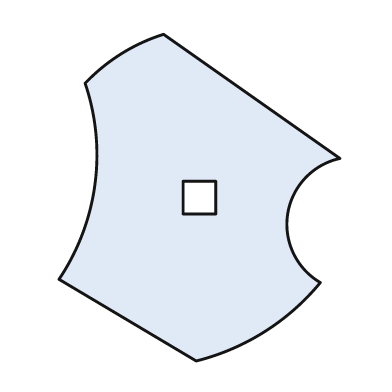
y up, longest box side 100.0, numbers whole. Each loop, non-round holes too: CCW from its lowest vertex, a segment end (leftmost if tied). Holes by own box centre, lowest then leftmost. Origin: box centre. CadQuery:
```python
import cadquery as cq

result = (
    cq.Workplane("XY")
    .moveTo(-1.0, -50.0)
    .threePointArc((20.0, -41.0), (37.0, -26.0))
    .threePointArc((27.0, -5.0), (43.0, 12.0))
    .lineTo(-11.0, 50.0)
    .threePointArc((-24.0, 44.0), (-35.0, 35.0))
    .threePointArc((-32.0, 4.0), (-43.0, -25.0))
    .close()
    .moveTo(-5.0, -5.0)
    .lineTo(5.0, -5.0)
    .lineTo(5.0, 5.0)
    .lineTo(-5.0, 5.0)
    .close()
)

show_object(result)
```